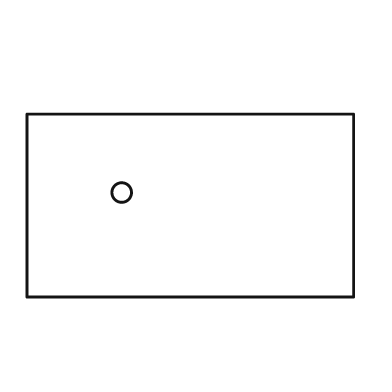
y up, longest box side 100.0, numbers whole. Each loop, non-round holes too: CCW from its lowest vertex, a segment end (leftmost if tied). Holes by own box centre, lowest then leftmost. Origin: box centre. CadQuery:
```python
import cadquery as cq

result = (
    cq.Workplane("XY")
    .moveTo(-50.0, -28.0)
    .lineTo(50.0, -28.0)
    .lineTo(50.0, 28.0)
    .lineTo(-50.0, 28.0)
    .close()
    .moveTo(-21.0, 4.0)
    .circle(3.0)
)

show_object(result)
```